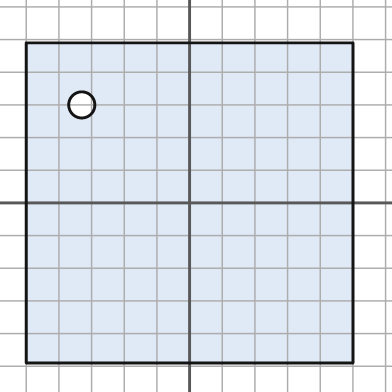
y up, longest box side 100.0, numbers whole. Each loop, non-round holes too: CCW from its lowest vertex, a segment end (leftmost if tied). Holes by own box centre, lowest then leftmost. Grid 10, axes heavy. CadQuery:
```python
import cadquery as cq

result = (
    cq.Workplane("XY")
    .moveTo(-50.0, -49.0)
    .lineTo(50.0, -49.0)
    .lineTo(50.0, 49.0)
    .lineTo(-50.0, 49.0)
    .close()
    .moveTo(-33.0, 30.0)
    .circle(4.0)
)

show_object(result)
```